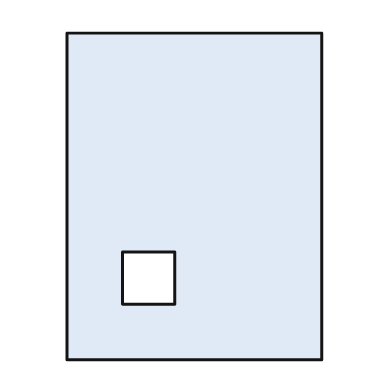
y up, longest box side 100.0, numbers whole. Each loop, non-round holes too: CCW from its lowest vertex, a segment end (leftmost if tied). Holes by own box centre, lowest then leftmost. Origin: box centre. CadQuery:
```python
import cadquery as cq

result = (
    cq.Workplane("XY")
    .moveTo(-39.0, -50.0)
    .lineTo(39.0, -50.0)
    .lineTo(39.0, 50.0)
    .lineTo(-39.0, 50.0)
    .close()
    .moveTo(-22.0, -33.0)
    .lineTo(-6.0, -33.0)
    .lineTo(-6.0, -17.0)
    .lineTo(-22.0, -17.0)
    .close()
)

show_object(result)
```